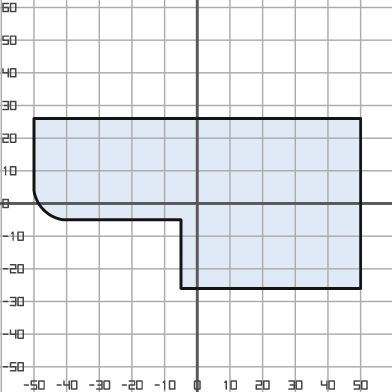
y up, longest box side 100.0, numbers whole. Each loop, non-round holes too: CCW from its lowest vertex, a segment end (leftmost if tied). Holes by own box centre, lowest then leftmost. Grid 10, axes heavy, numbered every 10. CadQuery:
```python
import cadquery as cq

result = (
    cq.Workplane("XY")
    .moveTo(-5.0, -26.0)
    .lineTo(50.0, -26.0)
    .lineTo(50.0, 26.0)
    .lineTo(-50.0, 26.0)
    .lineTo(-50.0, 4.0)
    .threePointArc((-47.0, -2.0), (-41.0, -5.0))
    .lineTo(-5.0, -5.0)
    .close()
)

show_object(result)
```